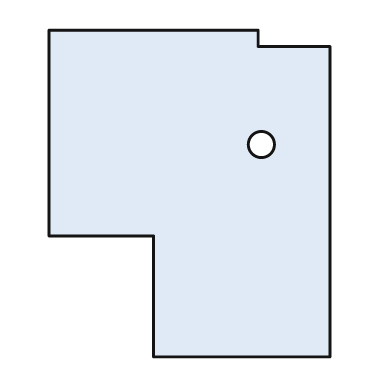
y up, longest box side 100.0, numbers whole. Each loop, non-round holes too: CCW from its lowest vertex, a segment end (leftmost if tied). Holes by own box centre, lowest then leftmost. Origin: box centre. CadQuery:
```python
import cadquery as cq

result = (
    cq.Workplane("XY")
    .moveTo(-11.0, -50.0)
    .lineTo(43.0, -50.0)
    .lineTo(43.0, 45.0)
    .lineTo(21.0, 45.0)
    .lineTo(21.0, 50.0)
    .lineTo(-43.0, 50.0)
    .lineTo(-43.0, -13.0)
    .lineTo(-11.0, -13.0)
    .close()
    .moveTo(22.0, 15.0)
    .circle(4.0)
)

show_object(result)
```